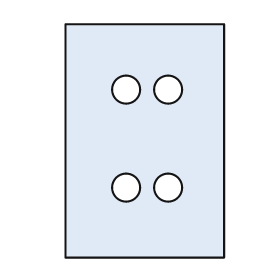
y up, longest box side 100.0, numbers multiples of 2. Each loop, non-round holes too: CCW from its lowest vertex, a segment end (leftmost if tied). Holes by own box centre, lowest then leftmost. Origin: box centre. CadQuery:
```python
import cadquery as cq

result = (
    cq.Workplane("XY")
    .moveTo(-34.0, -50.0)
    .lineTo(34.0, -50.0)
    .lineTo(34.0, 50.0)
    .lineTo(-34.0, 50.0)
    .close()
    .moveTo(-8.0, -20.0)
    .circle(6.0)
    .moveTo(10.0, -20.0)
    .circle(6.0)
    .moveTo(-8.0, 22.0)
    .circle(6.0)
    .moveTo(10.0, 22.0)
    .circle(6.0)
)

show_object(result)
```